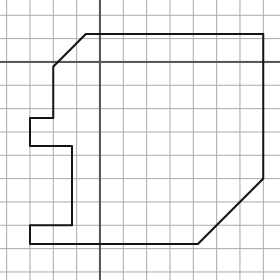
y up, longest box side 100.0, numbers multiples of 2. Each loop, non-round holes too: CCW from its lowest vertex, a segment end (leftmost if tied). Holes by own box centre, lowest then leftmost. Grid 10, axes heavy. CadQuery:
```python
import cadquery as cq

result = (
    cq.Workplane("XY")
    .moveTo(-30.0, -78.0)
    .lineTo(42.0, -78.0)
    .lineTo(70.0, -50.0)
    .lineTo(70.0, 12.0)
    .lineTo(-6.0, 12.0)
    .lineTo(-20.0, -2.0)
    .lineTo(-20.0, -24.0)
    .lineTo(-30.0, -24.0)
    .lineTo(-30.0, -36.0)
    .lineTo(-12.0, -36.0)
    .lineTo(-12.0, -70.0)
    .lineTo(-30.0, -70.0)
    .close()
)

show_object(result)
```